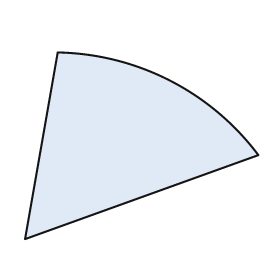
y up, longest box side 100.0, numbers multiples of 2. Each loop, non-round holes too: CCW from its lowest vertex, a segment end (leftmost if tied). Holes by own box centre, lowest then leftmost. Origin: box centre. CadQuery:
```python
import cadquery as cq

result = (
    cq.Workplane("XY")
    .moveTo(-50.0, -40.0)
    .lineTo(50.0, -4.0)
    .threePointArc((12.0, 28.0), (-36.0, 40.0))
    .close()
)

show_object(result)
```